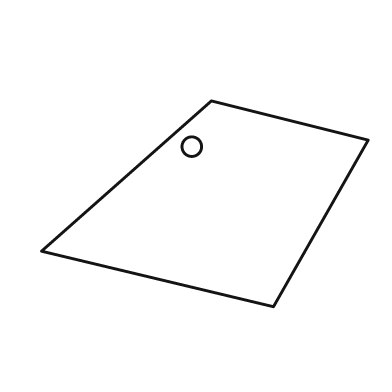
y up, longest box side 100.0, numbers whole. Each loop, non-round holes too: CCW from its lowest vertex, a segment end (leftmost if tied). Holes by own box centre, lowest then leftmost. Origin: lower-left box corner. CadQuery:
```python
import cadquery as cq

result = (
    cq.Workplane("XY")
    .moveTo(71.0, 0.0)
    .lineTo(100.0, 51.0)
    .lineTo(52.0, 63.0)
    .lineTo(0.0, 17.0)
    .close()
    .moveTo(46.0, 49.0)
    .circle(3.0)
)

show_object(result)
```